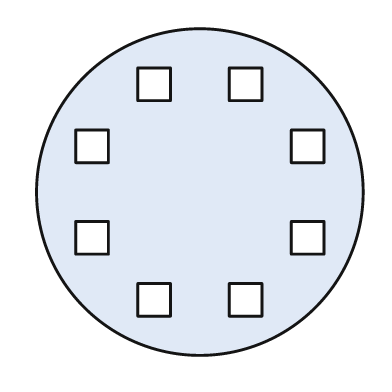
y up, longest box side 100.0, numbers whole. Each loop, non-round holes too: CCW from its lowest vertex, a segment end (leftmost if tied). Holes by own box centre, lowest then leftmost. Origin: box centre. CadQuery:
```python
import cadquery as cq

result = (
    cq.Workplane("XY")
    .moveTo(0.0, 0.0)
    .circle(50.0)
    .moveTo(-19.0, -38.0)
    .lineTo(-9.0, -38.0)
    .lineTo(-9.0, -28.0)
    .lineTo(-19.0, -28.0)
    .close()
    .moveTo(9.0, -38.0)
    .lineTo(19.0, -38.0)
    .lineTo(19.0, -28.0)
    .lineTo(9.0, -28.0)
    .close()
    .moveTo(-38.0, -19.0)
    .lineTo(-28.0, -19.0)
    .lineTo(-28.0, -9.0)
    .lineTo(-38.0, -9.0)
    .close()
    .moveTo(28.0, -19.0)
    .lineTo(38.0, -19.0)
    .lineTo(38.0, -9.0)
    .lineTo(28.0, -9.0)
    .close()
    .moveTo(-38.0, 9.0)
    .lineTo(-28.0, 9.0)
    .lineTo(-28.0, 19.0)
    .lineTo(-38.0, 19.0)
    .close()
    .moveTo(28.0, 9.0)
    .lineTo(38.0, 9.0)
    .lineTo(38.0, 19.0)
    .lineTo(28.0, 19.0)
    .close()
    .moveTo(-19.0, 28.0)
    .lineTo(-9.0, 28.0)
    .lineTo(-9.0, 38.0)
    .lineTo(-19.0, 38.0)
    .close()
    .moveTo(9.0, 28.0)
    .lineTo(19.0, 28.0)
    .lineTo(19.0, 38.0)
    .lineTo(9.0, 38.0)
    .close()
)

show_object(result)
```